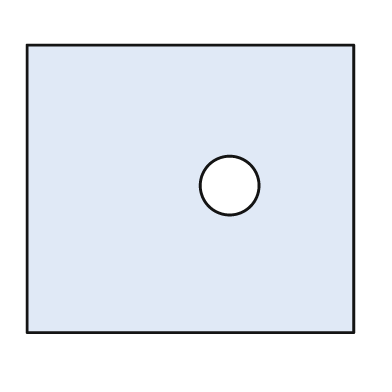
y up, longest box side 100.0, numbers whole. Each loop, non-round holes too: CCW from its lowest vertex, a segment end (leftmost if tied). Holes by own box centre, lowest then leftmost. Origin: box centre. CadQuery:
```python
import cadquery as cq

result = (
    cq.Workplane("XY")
    .moveTo(-50.0, -44.0)
    .lineTo(50.0, -44.0)
    .lineTo(50.0, 44.0)
    .lineTo(-50.0, 44.0)
    .close()
    .moveTo(12.0, 1.0)
    .circle(9.0)
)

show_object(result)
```